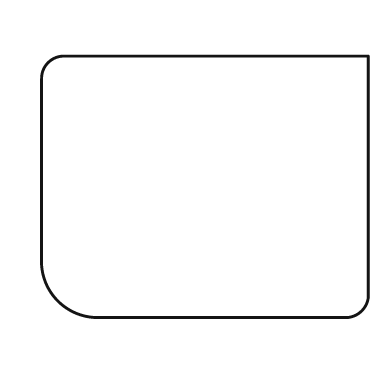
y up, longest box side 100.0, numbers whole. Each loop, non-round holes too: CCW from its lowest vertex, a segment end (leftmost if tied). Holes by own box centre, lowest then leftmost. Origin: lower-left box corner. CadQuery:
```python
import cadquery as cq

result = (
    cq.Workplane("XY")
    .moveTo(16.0, 0.0)
    .lineTo(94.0, 0.0)
    .threePointArc((98.0, 2.0), (100.0, 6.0))
    .lineTo(100.0, 80.0)
    .lineTo(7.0, 80.0)
    .threePointArc((2.0, 78.0), (0.0, 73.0))
    .lineTo(0.0, 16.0)
    .threePointArc((5.0, 5.0), (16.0, 0.0))
    .close()
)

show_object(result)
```